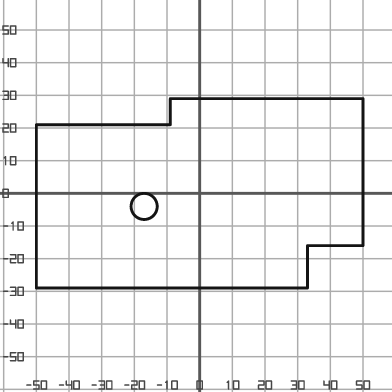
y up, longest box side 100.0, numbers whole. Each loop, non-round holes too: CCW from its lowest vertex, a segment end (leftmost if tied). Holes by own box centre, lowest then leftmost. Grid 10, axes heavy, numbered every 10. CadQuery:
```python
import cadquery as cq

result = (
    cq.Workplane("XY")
    .moveTo(-50.0, -29.0)
    .lineTo(33.0, -29.0)
    .lineTo(33.0, -16.0)
    .lineTo(50.0, -16.0)
    .lineTo(50.0, 29.0)
    .lineTo(-9.0, 29.0)
    .lineTo(-9.0, 21.0)
    .lineTo(-50.0, 21.0)
    .close()
    .moveTo(-17.0, -4.0)
    .circle(4.0)
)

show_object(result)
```